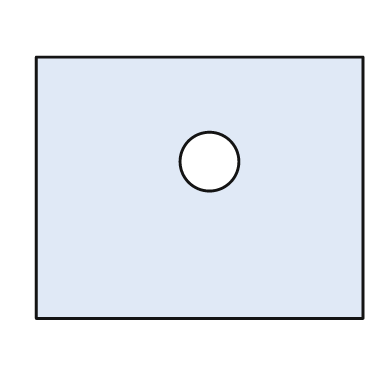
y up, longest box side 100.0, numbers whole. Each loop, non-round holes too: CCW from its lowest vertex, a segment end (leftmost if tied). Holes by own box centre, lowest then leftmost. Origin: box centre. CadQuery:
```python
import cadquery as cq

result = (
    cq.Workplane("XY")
    .moveTo(-50.0, -40.0)
    .lineTo(50.0, -40.0)
    .lineTo(50.0, 40.0)
    .lineTo(-50.0, 40.0)
    .close()
    .moveTo(3.0, 8.0)
    .circle(9.0)
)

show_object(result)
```